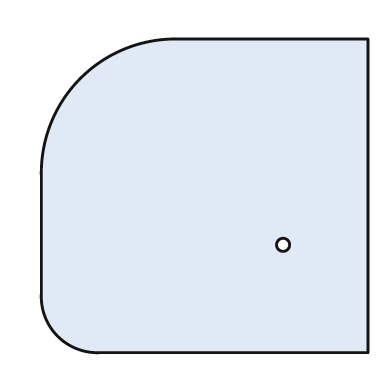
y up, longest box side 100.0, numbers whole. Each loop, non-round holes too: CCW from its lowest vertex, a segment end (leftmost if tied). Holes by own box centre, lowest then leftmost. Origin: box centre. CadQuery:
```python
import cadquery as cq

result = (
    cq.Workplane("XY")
    .moveTo(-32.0, -48.0)
    .lineTo(50.0, -48.0)
    .lineTo(50.0, 48.0)
    .lineTo(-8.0, 48.0)
    .threePointArc((-38.0, 36.0), (-50.0, 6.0))
    .lineTo(-50.0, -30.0)
    .threePointArc((-45.0, -43.0), (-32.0, -48.0))
    .close()
    .moveTo(24.0, -15.0)
    .circle(2.0)
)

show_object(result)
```